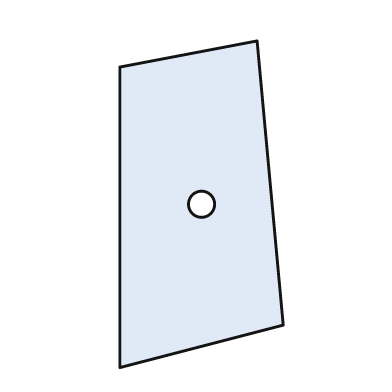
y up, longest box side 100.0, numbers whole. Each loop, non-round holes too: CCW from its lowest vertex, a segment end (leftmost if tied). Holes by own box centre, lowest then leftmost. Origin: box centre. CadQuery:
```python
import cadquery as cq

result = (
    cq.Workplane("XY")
    .moveTo(-25.0, -50.0)
    .lineTo(25.0, -37.0)
    .lineTo(17.0, 50.0)
    .lineTo(-25.0, 42.0)
    .close()
    .moveTo(0.0, 0.0)
    .circle(4.0)
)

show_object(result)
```